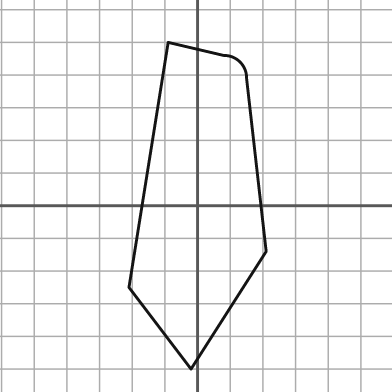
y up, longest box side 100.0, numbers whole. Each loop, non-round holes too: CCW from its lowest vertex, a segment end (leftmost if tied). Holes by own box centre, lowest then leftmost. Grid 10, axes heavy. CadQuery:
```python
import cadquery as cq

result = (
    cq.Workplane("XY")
    .moveTo(-2.0, -50.0)
    .lineTo(21.0, -14.0)
    .lineTo(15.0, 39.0)
    .threePointArc((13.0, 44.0), (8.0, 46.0))
    .lineTo(-9.0, 50.0)
    .lineTo(-21.0, -25.0)
    .close()
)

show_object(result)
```